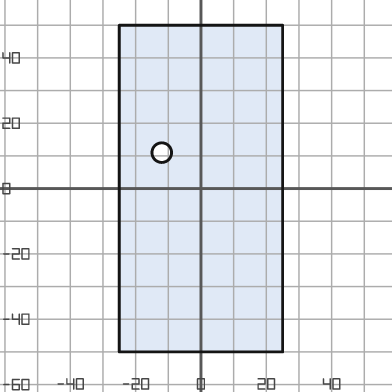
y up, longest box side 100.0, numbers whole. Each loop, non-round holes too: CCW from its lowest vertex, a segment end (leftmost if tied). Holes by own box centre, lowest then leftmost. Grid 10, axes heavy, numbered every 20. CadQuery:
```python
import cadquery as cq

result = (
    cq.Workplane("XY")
    .moveTo(-25.0, -50.0)
    .lineTo(25.0, -50.0)
    .lineTo(25.0, 50.0)
    .lineTo(-25.0, 50.0)
    .close()
    .moveTo(-12.0, 11.0)
    .circle(3.0)
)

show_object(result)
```